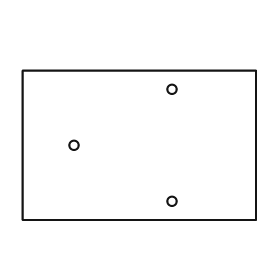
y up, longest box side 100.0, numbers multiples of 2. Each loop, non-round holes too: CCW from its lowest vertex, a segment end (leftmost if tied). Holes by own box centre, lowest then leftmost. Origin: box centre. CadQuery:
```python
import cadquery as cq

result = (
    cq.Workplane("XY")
    .moveTo(-50.0, -32.0)
    .lineTo(50.0, -32.0)
    .lineTo(50.0, 32.0)
    .lineTo(-50.0, 32.0)
    .close()
    .moveTo(14.0, -24.0)
    .circle(2.0)
    .moveTo(-28.0, 0.0)
    .circle(2.0)
    .moveTo(14.0, 24.0)
    .circle(2.0)
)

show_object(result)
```